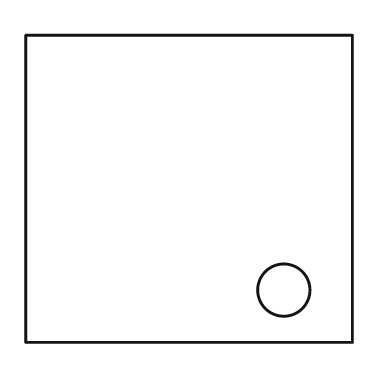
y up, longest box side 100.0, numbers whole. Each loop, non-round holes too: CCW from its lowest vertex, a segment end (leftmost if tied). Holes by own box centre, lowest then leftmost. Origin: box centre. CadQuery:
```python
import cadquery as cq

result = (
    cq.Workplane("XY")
    .moveTo(-50.0, -47.0)
    .lineTo(50.0, -47.0)
    .lineTo(50.0, 47.0)
    .lineTo(-50.0, 47.0)
    .close()
    .moveTo(29.0, -31.0)
    .circle(8.0)
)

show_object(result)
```